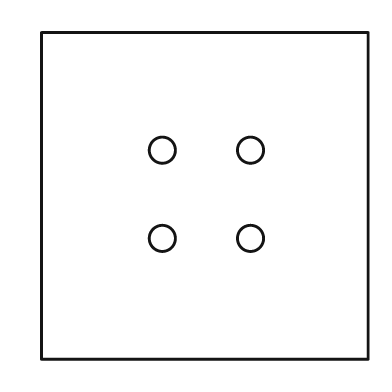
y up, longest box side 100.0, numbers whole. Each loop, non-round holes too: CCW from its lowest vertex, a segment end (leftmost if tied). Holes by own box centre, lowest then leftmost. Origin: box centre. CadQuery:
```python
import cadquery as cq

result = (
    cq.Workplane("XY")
    .moveTo(-50.0, -50.0)
    .lineTo(50.0, -50.0)
    .lineTo(50.0, 50.0)
    .lineTo(-50.0, 50.0)
    .close()
    .moveTo(-13.0, -13.0)
    .circle(4.0)
    .moveTo(14.0, -13.0)
    .circle(4.0)
    .moveTo(-13.0, 14.0)
    .circle(4.0)
    .moveTo(14.0, 14.0)
    .circle(4.0)
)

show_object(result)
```